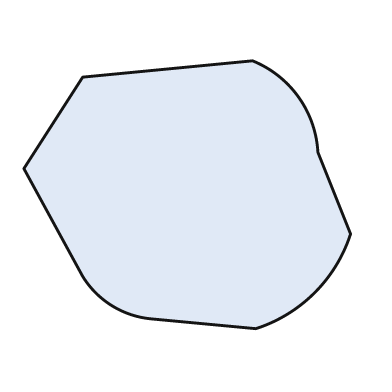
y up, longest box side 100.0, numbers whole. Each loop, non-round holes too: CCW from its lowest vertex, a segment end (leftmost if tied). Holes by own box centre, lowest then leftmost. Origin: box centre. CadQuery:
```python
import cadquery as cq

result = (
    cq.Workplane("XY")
    .moveTo(21.0, -41.0)
    .threePointArc((39.0, -30.0), (50.0, -12.0))
    .lineTo(40.0, 13.0)
    .threePointArc((34.0, 30.0), (20.0, 41.0))
    .lineTo(-32.0, 36.0)
    .lineTo(-50.0, 8.0)
    .lineTo(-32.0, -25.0)
    .threePointArc((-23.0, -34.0), (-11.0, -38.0))
    .close()
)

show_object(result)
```